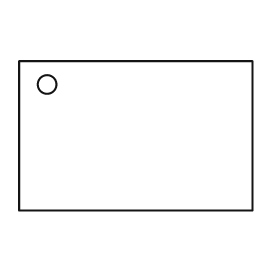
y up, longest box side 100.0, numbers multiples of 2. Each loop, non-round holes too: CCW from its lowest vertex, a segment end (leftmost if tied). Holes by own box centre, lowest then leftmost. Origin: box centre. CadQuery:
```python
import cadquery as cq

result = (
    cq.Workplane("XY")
    .moveTo(-50.0, -32.0)
    .lineTo(50.0, -32.0)
    .lineTo(50.0, 32.0)
    .lineTo(-50.0, 32.0)
    .close()
    .moveTo(-38.0, 22.0)
    .circle(4.0)
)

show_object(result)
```